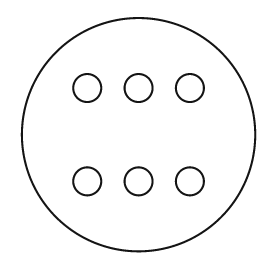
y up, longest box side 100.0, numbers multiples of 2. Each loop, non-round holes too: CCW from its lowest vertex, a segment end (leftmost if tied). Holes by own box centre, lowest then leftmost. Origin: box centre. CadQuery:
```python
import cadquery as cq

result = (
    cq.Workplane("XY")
    .moveTo(0.0, 0.0)
    .circle(50.0)
    .moveTo(-22.0, -20.0)
    .circle(6.0)
    .moveTo(0.0, -20.0)
    .circle(6.0)
    .moveTo(22.0, -20.0)
    .circle(6.0)
    .moveTo(-22.0, 20.0)
    .circle(6.0)
    .moveTo(0.0, 20.0)
    .circle(6.0)
    .moveTo(22.0, 20.0)
    .circle(6.0)
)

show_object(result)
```